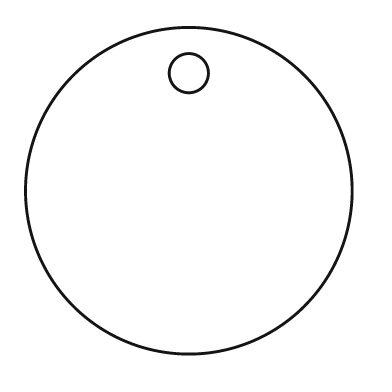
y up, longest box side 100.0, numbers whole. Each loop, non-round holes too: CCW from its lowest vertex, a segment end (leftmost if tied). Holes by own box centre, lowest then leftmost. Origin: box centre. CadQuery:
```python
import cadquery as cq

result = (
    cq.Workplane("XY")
    .moveTo(0.0, 0.0)
    .circle(50.0)
    .moveTo(0.0, 36.0)
    .circle(6.0)
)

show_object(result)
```